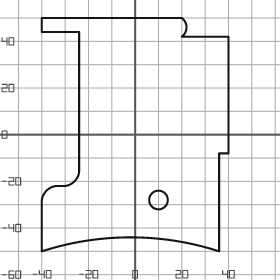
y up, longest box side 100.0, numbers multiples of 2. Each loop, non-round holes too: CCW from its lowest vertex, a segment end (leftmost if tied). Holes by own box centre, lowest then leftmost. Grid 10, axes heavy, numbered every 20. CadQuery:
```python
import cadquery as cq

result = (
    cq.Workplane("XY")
    .moveTo(-40.0, -50.0)
    .threePointArc((-2.0, -44.0), (36.0, -50.0))
    .lineTo(36.0, -8.0)
    .lineTo(40.0, -8.0)
    .lineTo(40.0, 42.0)
    .lineTo(20.0, 42.0)
    .threePointArc((22.0, 46.0), (20.0, 50.0))
    .lineTo(-40.0, 50.0)
    .lineTo(-40.0, 44.0)
    .lineTo(-24.0, 44.0)
    .lineTo(-24.0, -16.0)
    .threePointArc((-26.0, -20.0), (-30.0, -22.0))
    .lineTo(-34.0, -22.0)
    .threePointArc((-38.0, -24.0), (-40.0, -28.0))
    .close()
    .moveTo(10.0, -28.0)
    .circle(4.0)
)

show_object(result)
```